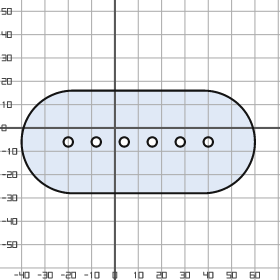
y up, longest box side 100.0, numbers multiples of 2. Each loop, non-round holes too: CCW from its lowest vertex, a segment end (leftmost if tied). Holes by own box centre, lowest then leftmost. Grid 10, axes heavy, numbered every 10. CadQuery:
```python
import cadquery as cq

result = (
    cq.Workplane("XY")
    .moveTo(-18.0, -28.0)
    .lineTo(38.0, -28.0)
    .threePointArc((60.0, -6.0), (38.0, 16.0))
    .lineTo(-18.0, 16.0)
    .threePointArc((-40.0, -6.0), (-18.0, -28.0))
    .close()
    .moveTo(-20.0, -6.0)
    .circle(2.0)
    .moveTo(-8.0, -6.0)
    .circle(2.0)
    .moveTo(4.0, -6.0)
    .circle(2.0)
    .moveTo(16.0, -6.0)
    .circle(2.0)
    .moveTo(28.0, -6.0)
    .circle(2.0)
    .moveTo(40.0, -6.0)
    .circle(2.0)
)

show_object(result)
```